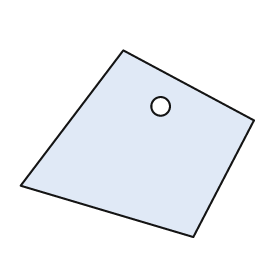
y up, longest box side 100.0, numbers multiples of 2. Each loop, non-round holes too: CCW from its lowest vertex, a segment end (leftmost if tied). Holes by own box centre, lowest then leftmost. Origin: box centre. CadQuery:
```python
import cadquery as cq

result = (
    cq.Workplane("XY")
    .moveTo(24.0, -40.0)
    .lineTo(50.0, 10.0)
    .lineTo(-6.0, 40.0)
    .lineTo(-50.0, -18.0)
    .close()
    .moveTo(10.0, 16.0)
    .circle(4.0)
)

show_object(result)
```